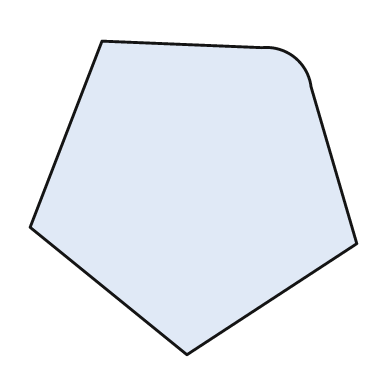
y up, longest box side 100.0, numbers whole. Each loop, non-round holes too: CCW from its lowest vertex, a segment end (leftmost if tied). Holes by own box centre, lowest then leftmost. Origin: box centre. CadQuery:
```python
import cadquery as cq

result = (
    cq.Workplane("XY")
    .moveTo(-2.0, -48.0)
    .lineTo(50.0, -14.0)
    .lineTo(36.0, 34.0)
    .threePointArc((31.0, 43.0), (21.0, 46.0))
    .lineTo(-28.0, 48.0)
    .lineTo(-50.0, -9.0)
    .close()
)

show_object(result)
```